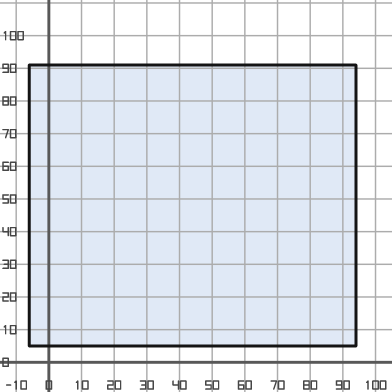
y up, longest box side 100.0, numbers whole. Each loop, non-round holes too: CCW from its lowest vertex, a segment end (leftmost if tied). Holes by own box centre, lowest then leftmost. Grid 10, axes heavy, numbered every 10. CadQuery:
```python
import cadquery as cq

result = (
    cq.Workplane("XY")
    .moveTo(-6.0, 5.0)
    .lineTo(94.0, 5.0)
    .lineTo(94.0, 91.0)
    .lineTo(-6.0, 91.0)
    .close()
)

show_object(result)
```